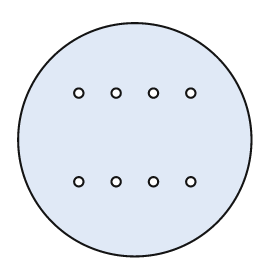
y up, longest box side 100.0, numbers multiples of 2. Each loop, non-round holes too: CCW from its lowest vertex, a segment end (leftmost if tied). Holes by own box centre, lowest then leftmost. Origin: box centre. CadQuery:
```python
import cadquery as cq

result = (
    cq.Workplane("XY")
    .moveTo(0.0, 0.0)
    .circle(50.0)
    .moveTo(-24.0, -18.0)
    .circle(2.0)
    .moveTo(-8.0, -18.0)
    .circle(2.0)
    .moveTo(8.0, -18.0)
    .circle(2.0)
    .moveTo(24.0, -18.0)
    .circle(2.0)
    .moveTo(-24.0, 20.0)
    .circle(2.0)
    .moveTo(-8.0, 20.0)
    .circle(2.0)
    .moveTo(8.0, 20.0)
    .circle(2.0)
    .moveTo(24.0, 20.0)
    .circle(2.0)
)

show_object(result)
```